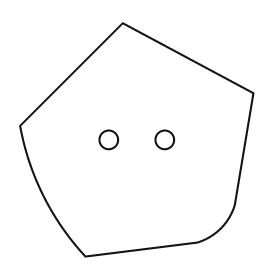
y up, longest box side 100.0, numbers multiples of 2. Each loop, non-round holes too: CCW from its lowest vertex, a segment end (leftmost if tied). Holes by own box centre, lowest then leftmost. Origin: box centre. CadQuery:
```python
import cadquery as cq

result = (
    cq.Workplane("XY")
    .moveTo(-22.0, -50.0)
    .lineTo(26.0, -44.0)
    .threePointArc((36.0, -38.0), (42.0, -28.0))
    .lineTo(50.0, 20.0)
    .lineTo(-6.0, 50.0)
    .lineTo(-50.0, 6.0)
    .threePointArc((-40.0, -24.0), (-22.0, -50.0))
    .close()
    .moveTo(-12.0, 0.0)
    .circle(4.0)
    .moveTo(12.0, 0.0)
    .circle(4.0)
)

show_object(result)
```